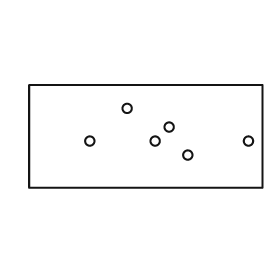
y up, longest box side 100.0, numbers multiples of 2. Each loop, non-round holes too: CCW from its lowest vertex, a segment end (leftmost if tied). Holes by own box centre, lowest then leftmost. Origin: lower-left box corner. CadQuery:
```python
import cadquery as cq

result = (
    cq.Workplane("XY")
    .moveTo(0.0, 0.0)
    .lineTo(100.0, 0.0)
    .lineTo(100.0, 44.0)
    .lineTo(0.0, 44.0)
    .close()
    .moveTo(68.0, 14.0)
    .circle(2.0)
    .moveTo(26.0, 20.0)
    .circle(2.0)
    .moveTo(54.0, 20.0)
    .circle(2.0)
    .moveTo(94.0, 20.0)
    .circle(2.0)
    .moveTo(60.0, 26.0)
    .circle(2.0)
    .moveTo(42.0, 34.0)
    .circle(2.0)
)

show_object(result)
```